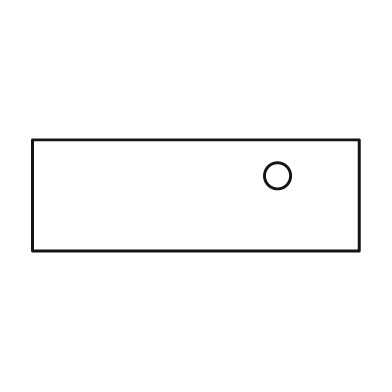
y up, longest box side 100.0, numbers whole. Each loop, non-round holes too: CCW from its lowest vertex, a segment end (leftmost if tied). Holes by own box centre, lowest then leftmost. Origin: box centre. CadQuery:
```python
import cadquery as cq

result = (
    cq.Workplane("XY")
    .moveTo(-50.0, -17.0)
    .lineTo(50.0, -17.0)
    .lineTo(50.0, 17.0)
    .lineTo(-50.0, 17.0)
    .close()
    .moveTo(25.0, 6.0)
    .circle(4.0)
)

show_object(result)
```